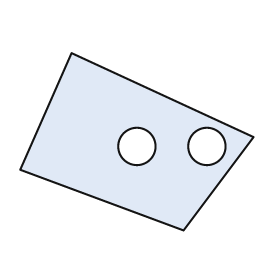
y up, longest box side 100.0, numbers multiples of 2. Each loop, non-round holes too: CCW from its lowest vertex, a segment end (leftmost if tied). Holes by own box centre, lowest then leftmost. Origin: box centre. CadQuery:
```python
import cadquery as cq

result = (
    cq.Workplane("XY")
    .moveTo(20.0, -38.0)
    .lineTo(50.0, 2.0)
    .lineTo(-28.0, 38.0)
    .lineTo(-50.0, -12.0)
    .close()
    .moveTo(0.0, -2.0)
    .circle(8.0)
    .moveTo(30.0, -2.0)
    .circle(8.0)
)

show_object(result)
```